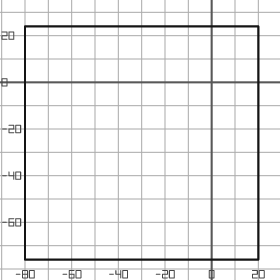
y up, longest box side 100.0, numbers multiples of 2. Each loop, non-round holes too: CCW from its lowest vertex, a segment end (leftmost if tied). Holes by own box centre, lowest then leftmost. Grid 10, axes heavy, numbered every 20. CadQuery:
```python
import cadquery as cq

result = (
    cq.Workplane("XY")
    .moveTo(-80.0, -76.0)
    .lineTo(20.0, -76.0)
    .lineTo(20.0, 24.0)
    .lineTo(-80.0, 24.0)
    .close()
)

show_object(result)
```